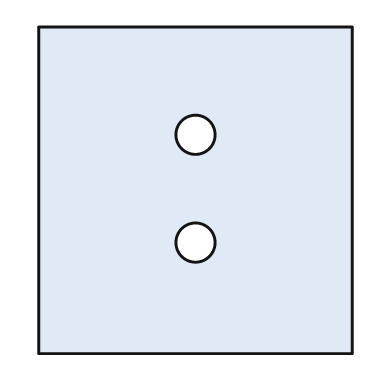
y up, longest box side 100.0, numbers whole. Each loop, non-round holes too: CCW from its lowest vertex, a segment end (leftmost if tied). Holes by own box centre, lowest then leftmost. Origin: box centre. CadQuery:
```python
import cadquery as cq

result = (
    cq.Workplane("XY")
    .moveTo(-48.0, -50.0)
    .lineTo(48.0, -50.0)
    .lineTo(48.0, 50.0)
    .lineTo(-48.0, 50.0)
    .close()
    .moveTo(0.0, -16.0)
    .circle(6.0)
    .moveTo(0.0, 17.0)
    .circle(6.0)
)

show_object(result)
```